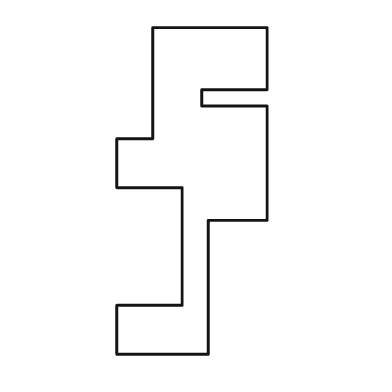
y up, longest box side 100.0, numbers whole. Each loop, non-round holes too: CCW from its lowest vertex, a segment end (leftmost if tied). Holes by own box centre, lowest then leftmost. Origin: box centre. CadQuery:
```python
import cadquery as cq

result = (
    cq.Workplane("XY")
    .moveTo(-23.0, -50.0)
    .lineTo(5.0, -50.0)
    .lineTo(5.0, -9.0)
    .lineTo(23.0, -9.0)
    .lineTo(23.0, 26.0)
    .lineTo(3.0, 26.0)
    .lineTo(3.0, 31.0)
    .lineTo(23.0, 31.0)
    .lineTo(23.0, 50.0)
    .lineTo(-12.0, 50.0)
    .lineTo(-12.0, 16.0)
    .lineTo(-23.0, 16.0)
    .lineTo(-23.0, 1.0)
    .lineTo(-3.0, 1.0)
    .lineTo(-3.0, -35.0)
    .lineTo(-23.0, -35.0)
    .close()
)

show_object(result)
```